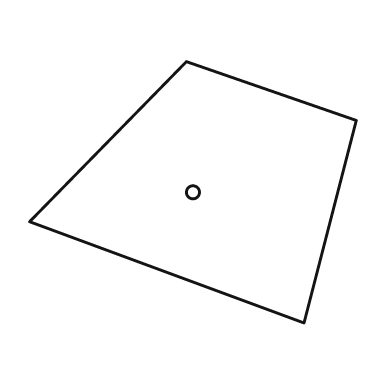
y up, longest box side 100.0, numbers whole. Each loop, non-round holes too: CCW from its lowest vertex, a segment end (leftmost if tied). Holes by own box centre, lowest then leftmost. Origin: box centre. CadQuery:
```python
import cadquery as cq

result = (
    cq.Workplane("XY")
    .moveTo(34.0, -40.0)
    .lineTo(50.0, 22.0)
    .lineTo(-2.0, 40.0)
    .lineTo(-50.0, -9.0)
    .close()
    .moveTo(0.0, 0.0)
    .circle(2.0)
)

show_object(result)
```